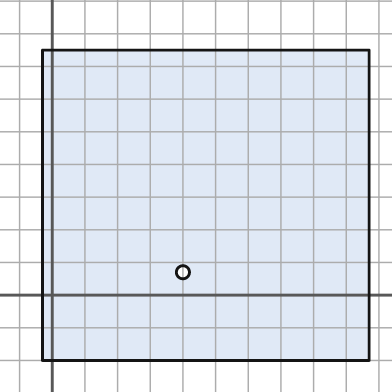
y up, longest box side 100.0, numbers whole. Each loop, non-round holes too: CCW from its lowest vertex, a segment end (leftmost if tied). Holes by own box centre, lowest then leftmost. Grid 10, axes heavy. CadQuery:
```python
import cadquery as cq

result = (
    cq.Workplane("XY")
    .moveTo(-3.0, -20.0)
    .lineTo(97.0, -20.0)
    .lineTo(97.0, 75.0)
    .lineTo(-3.0, 75.0)
    .close()
    .moveTo(40.0, 7.0)
    .circle(2.0)
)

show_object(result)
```